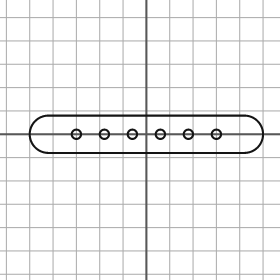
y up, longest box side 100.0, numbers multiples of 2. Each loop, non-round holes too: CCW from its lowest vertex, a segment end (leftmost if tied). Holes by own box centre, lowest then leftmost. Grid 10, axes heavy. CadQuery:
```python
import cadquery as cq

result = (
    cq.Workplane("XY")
    .moveTo(-42.0, -8.0)
    .lineTo(42.0, -8.0)
    .threePointArc((50.0, 0.0), (42.0, 8.0))
    .lineTo(-42.0, 8.0)
    .threePointArc((-50.0, 0.0), (-42.0, -8.0))
    .close()
    .moveTo(-30.0, 0.0)
    .circle(2.0)
    .moveTo(-18.0, 0.0)
    .circle(2.0)
    .moveTo(-6.0, 0.0)
    .circle(2.0)
    .moveTo(6.0, 0.0)
    .circle(2.0)
    .moveTo(18.0, 0.0)
    .circle(2.0)
    .moveTo(30.0, 0.0)
    .circle(2.0)
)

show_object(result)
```